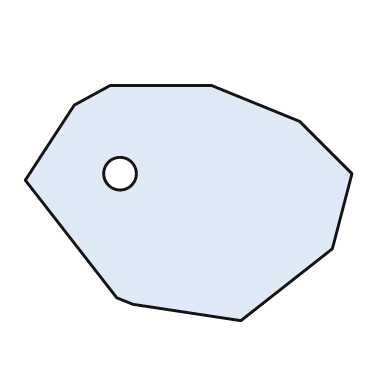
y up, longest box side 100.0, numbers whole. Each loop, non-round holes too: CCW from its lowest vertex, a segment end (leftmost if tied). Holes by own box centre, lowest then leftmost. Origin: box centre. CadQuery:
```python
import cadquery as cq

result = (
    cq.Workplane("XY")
    .moveTo(16.0, -36.0)
    .lineTo(44.0, -14.0)
    .lineTo(50.0, 9.0)
    .lineTo(34.0, 25.0)
    .lineTo(7.0, 36.0)
    .lineTo(-24.0, 36.0)
    .lineTo(-35.0, 30.0)
    .lineTo(-50.0, 7.0)
    .lineTo(-22.0, -29.0)
    .lineTo(-17.0, -31.0)
    .close()
    .moveTo(-21.0, 9.0)
    .circle(5.0)
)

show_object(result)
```